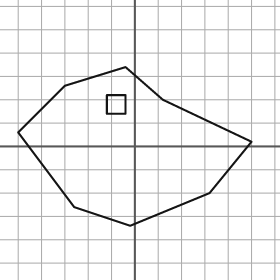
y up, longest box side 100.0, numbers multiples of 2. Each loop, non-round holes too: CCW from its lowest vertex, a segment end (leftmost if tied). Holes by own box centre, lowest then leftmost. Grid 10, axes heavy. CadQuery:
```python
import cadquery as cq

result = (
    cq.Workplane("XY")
    .moveTo(-2.0, -34.0)
    .lineTo(32.0, -20.0)
    .lineTo(50.0, 2.0)
    .lineTo(12.0, 20.0)
    .lineTo(-4.0, 34.0)
    .lineTo(-30.0, 26.0)
    .lineTo(-50.0, 6.0)
    .lineTo(-26.0, -26.0)
    .close()
    .moveTo(-12.0, 14.0)
    .lineTo(-4.0, 14.0)
    .lineTo(-4.0, 22.0)
    .lineTo(-12.0, 22.0)
    .close()
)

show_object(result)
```